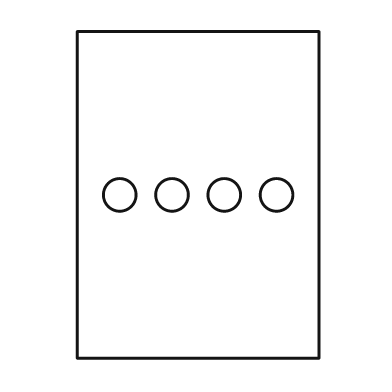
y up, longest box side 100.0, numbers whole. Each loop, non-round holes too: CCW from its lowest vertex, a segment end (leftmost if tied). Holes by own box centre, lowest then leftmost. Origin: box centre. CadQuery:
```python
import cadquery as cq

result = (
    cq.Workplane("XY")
    .moveTo(-37.0, -50.0)
    .lineTo(37.0, -50.0)
    .lineTo(37.0, 50.0)
    .lineTo(-37.0, 50.0)
    .close()
    .moveTo(-24.0, 0.0)
    .circle(5.0)
    .moveTo(-8.0, 0.0)
    .circle(5.0)
    .moveTo(8.0, 0.0)
    .circle(5.0)
    .moveTo(24.0, 0.0)
    .circle(5.0)
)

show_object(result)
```